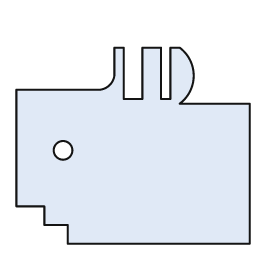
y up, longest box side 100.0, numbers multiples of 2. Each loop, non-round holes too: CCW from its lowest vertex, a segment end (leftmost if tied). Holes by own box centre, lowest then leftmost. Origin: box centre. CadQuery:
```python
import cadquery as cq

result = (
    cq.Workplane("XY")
    .moveTo(-28.0, -42.0)
    .lineTo(50.0, -42.0)
    .lineTo(50.0, 18.0)
    .lineTo(20.0, 18.0)
    .threePointArc((26.0, 30.0), (20.0, 42.0))
    .lineTo(16.0, 42.0)
    .lineTo(16.0, 20.0)
    .lineTo(12.0, 20.0)
    .lineTo(12.0, 42.0)
    .lineTo(4.0, 42.0)
    .lineTo(4.0, 20.0)
    .lineTo(-4.0, 20.0)
    .lineTo(-4.0, 42.0)
    .lineTo(-8.0, 42.0)
    .lineTo(-8.0, 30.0)
    .threePointArc((-10.0, 26.0), (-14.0, 24.0))
    .lineTo(-50.0, 24.0)
    .lineTo(-50.0, -26.0)
    .lineTo(-38.0, -26.0)
    .lineTo(-38.0, -34.0)
    .lineTo(-28.0, -34.0)
    .close()
    .moveTo(-30.0, -2.0)
    .circle(4.0)
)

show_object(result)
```